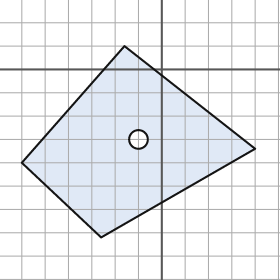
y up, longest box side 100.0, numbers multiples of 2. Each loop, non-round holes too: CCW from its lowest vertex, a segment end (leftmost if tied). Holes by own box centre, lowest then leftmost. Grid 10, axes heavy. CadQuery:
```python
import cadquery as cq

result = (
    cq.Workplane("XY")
    .moveTo(-26.0, -72.0)
    .lineTo(40.0, -34.0)
    .lineTo(-16.0, 10.0)
    .lineTo(-60.0, -40.0)
    .close()
    .moveTo(-10.0, -30.0)
    .circle(4.0)
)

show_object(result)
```